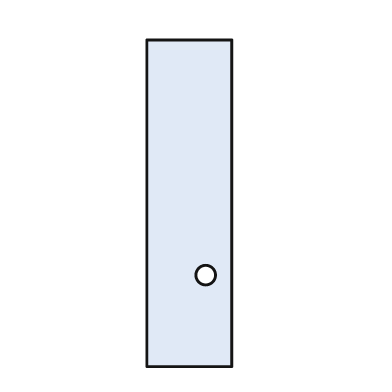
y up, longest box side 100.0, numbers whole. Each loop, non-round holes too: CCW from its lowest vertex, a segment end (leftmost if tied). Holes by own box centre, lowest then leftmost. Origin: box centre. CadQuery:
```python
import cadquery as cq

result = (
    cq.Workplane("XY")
    .moveTo(-13.0, -50.0)
    .lineTo(13.0, -50.0)
    .lineTo(13.0, 50.0)
    .lineTo(-13.0, 50.0)
    .close()
    .moveTo(5.0, -22.0)
    .circle(3.0)
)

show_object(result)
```